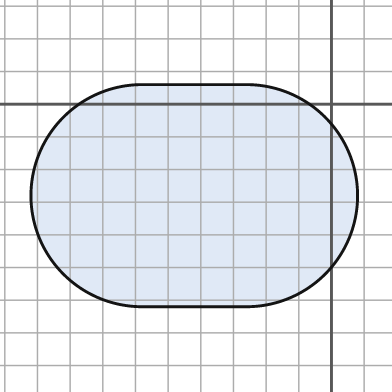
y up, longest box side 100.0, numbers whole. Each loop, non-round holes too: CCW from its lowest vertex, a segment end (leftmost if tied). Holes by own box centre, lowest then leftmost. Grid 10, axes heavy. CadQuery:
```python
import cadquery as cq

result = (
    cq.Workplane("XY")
    .moveTo(-58.0, -62.0)
    .lineTo(-26.0, -62.0)
    .threePointArc((8.0, -28.0), (-26.0, 6.0))
    .lineTo(-58.0, 6.0)
    .threePointArc((-92.0, -28.0), (-58.0, -62.0))
    .close()
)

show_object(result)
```